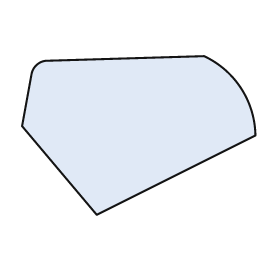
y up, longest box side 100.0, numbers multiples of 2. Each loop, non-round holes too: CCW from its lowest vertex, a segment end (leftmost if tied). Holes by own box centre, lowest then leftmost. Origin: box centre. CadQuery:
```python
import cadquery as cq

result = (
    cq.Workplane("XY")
    .moveTo(-18.0, -34.0)
    .lineTo(50.0, 0.0)
    .threePointArc((44.0, 20.0), (28.0, 34.0))
    .lineTo(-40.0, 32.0)
    .threePointArc((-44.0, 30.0), (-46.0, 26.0))
    .lineTo(-50.0, 4.0)
    .close()
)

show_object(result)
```